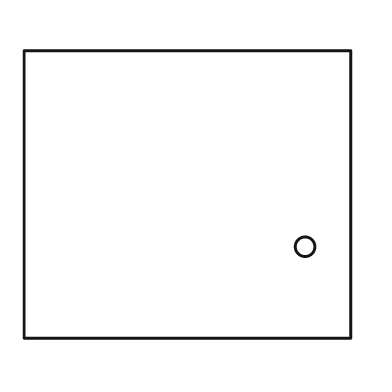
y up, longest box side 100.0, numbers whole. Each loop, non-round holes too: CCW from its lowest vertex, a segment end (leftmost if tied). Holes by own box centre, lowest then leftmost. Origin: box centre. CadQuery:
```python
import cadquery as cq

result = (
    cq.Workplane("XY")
    .moveTo(-50.0, -44.0)
    .lineTo(50.0, -44.0)
    .lineTo(50.0, 44.0)
    .lineTo(-50.0, 44.0)
    .close()
    .moveTo(36.0, -16.0)
    .circle(3.0)
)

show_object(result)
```